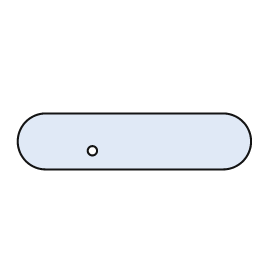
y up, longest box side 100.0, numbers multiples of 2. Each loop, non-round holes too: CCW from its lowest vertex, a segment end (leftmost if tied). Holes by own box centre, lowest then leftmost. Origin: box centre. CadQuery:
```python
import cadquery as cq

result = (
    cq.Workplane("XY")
    .moveTo(-38.0, -12.0)
    .lineTo(38.0, -12.0)
    .threePointArc((50.0, 0.0), (38.0, 12.0))
    .lineTo(-38.0, 12.0)
    .threePointArc((-50.0, 0.0), (-38.0, -12.0))
    .close()
    .moveTo(-18.0, -4.0)
    .circle(2.0)
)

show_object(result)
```